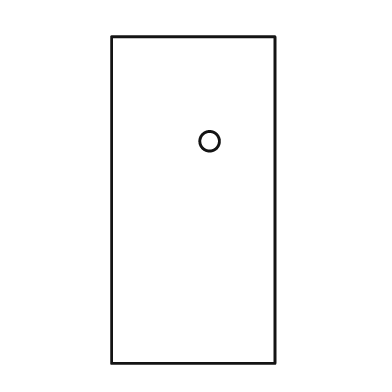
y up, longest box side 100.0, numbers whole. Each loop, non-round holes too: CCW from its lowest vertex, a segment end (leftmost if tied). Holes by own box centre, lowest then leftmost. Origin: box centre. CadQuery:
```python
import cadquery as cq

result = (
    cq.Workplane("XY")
    .moveTo(-25.0, -50.0)
    .lineTo(25.0, -50.0)
    .lineTo(25.0, 50.0)
    .lineTo(-25.0, 50.0)
    .close()
    .moveTo(5.0, 18.0)
    .circle(3.0)
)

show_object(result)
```